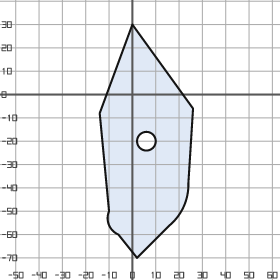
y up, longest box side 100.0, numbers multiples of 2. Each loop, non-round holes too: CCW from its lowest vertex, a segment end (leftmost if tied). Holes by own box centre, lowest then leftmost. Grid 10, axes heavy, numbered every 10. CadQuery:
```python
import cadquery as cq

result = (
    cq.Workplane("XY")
    .moveTo(2.0, -70.0)
    .lineTo(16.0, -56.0)
    .threePointArc((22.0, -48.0), (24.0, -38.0))
    .lineTo(26.0, -6.0)
    .lineTo(0.0, 30.0)
    .lineTo(-14.0, -8.0)
    .lineTo(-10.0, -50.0)
    .threePointArc((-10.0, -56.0), (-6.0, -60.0))
    .close()
    .moveTo(6.0, -20.0)
    .circle(4.0)
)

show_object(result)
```